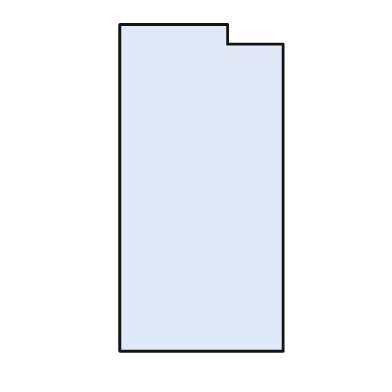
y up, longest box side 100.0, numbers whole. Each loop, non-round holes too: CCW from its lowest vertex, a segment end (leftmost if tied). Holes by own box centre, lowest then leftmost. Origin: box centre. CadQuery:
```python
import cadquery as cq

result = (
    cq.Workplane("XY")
    .moveTo(-25.0, -50.0)
    .lineTo(25.0, -50.0)
    .lineTo(25.0, 44.0)
    .lineTo(8.0, 44.0)
    .lineTo(8.0, 50.0)
    .lineTo(-25.0, 50.0)
    .close()
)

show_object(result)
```